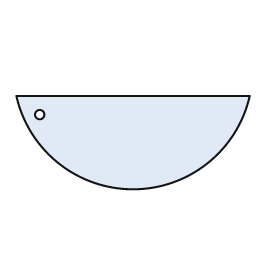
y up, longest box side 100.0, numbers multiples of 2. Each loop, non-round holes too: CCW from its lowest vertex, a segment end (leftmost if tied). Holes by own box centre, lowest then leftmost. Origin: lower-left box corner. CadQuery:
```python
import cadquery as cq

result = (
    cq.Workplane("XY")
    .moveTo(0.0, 40.0)
    .threePointArc((50.0, 0.0), (100.0, 40.0))
    .close()
    .moveTo(10.0, 32.0)
    .circle(2.0)
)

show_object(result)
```